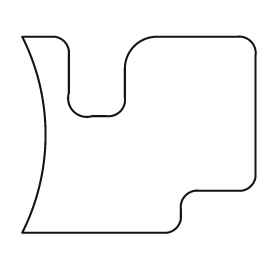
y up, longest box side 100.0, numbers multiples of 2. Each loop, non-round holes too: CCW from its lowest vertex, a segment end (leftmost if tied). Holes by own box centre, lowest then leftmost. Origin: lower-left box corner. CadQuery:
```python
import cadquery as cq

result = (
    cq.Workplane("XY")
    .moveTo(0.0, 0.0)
    .lineTo(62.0, 0.0)
    .threePointArc((66.0, 2.0), (68.0, 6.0))
    .lineTo(68.0, 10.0)
    .threePointArc((70.0, 16.0), (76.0, 18.0))
    .lineTo(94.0, 18.0)
    .threePointArc((98.0, 20.0), (100.0, 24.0))
    .lineTo(100.0, 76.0)
    .threePointArc((98.0, 82.0), (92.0, 84.0))
    .lineTo(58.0, 84.0)
    .threePointArc((48.0, 80.0), (44.0, 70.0))
    .lineTo(44.0, 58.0)
    .threePointArc((42.0, 52.0), (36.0, 50.0))
    .lineTo(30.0, 50.0)
    .threePointArc((22.0, 52.0), (20.0, 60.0))
    .lineTo(20.0, 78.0)
    .threePointArc((18.0, 82.0), (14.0, 84.0))
    .lineTo(0.0, 84.0)
    .threePointArc((10.0, 42.0), (0.0, 0.0))
    .close()
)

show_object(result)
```